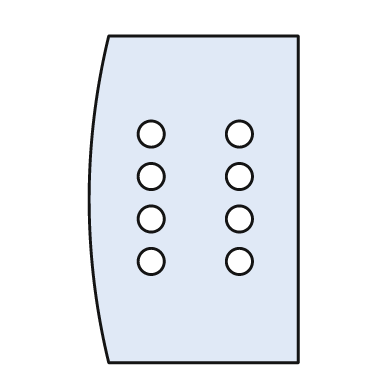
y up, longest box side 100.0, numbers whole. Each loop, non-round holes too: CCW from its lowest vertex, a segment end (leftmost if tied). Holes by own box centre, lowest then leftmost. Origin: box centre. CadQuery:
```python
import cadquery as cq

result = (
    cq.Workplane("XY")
    .moveTo(-26.0, -50.0)
    .lineTo(32.0, -50.0)
    .lineTo(32.0, 50.0)
    .lineTo(-26.0, 50.0)
    .threePointArc((-32.0, 0.0), (-26.0, -50.0))
    .close()
    .moveTo(-13.0, -19.0)
    .circle(4.0)
    .moveTo(14.0, -19.0)
    .circle(4.0)
    .moveTo(-13.0, -6.0)
    .circle(4.0)
    .moveTo(14.0, -6.0)
    .circle(4.0)
    .moveTo(-13.0, 7.0)
    .circle(4.0)
    .moveTo(14.0, 7.0)
    .circle(4.0)
    .moveTo(-13.0, 20.0)
    .circle(4.0)
    .moveTo(14.0, 20.0)
    .circle(4.0)
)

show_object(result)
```